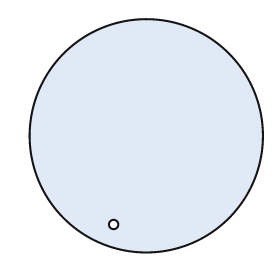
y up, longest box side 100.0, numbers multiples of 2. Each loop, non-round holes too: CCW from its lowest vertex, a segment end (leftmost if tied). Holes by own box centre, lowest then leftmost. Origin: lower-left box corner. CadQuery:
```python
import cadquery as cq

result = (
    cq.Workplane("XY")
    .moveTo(50.0, 50.0)
    .circle(50.0)
    .moveTo(36.0, 12.0)
    .circle(2.0)
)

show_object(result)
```